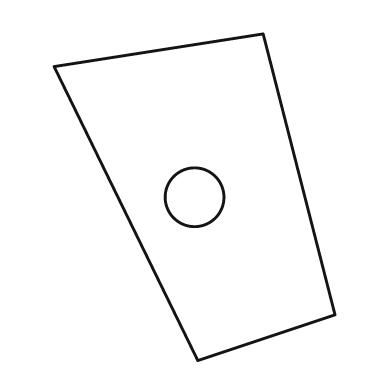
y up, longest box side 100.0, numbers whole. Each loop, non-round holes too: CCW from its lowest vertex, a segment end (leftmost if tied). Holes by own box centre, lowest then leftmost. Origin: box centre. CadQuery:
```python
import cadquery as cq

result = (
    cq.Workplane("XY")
    .moveTo(1.0, -50.0)
    .lineTo(43.0, -36.0)
    .lineTo(21.0, 50.0)
    .lineTo(-43.0, 40.0)
    .close()
    .moveTo(0.0, 0.0)
    .circle(9.0)
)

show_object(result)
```